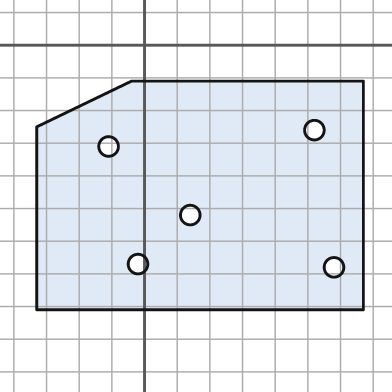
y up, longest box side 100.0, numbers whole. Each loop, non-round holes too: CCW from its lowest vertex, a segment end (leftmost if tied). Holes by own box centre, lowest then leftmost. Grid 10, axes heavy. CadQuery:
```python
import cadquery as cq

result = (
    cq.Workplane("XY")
    .moveTo(-33.0, -81.0)
    .lineTo(67.0, -81.0)
    .lineTo(67.0, -11.0)
    .lineTo(-4.0, -11.0)
    .lineTo(-33.0, -25.0)
    .close()
    .moveTo(58.0, -68.0)
    .circle(3.0)
    .moveTo(-2.0, -67.0)
    .circle(3.0)
    .moveTo(14.0, -52.0)
    .circle(3.0)
    .moveTo(-11.0, -31.0)
    .circle(3.0)
    .moveTo(52.0, -26.0)
    .circle(3.0)
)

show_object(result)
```